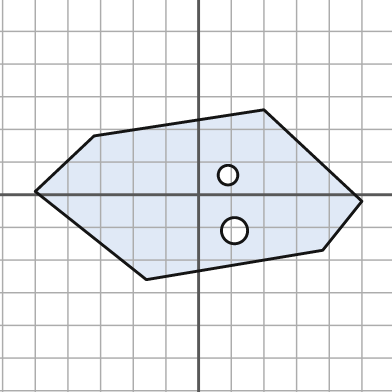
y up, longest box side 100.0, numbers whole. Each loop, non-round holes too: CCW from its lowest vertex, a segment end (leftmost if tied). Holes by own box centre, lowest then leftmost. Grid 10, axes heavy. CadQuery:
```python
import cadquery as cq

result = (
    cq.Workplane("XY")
    .moveTo(-16.0, -26.0)
    .lineTo(38.0, -17.0)
    .lineTo(50.0, -2.0)
    .lineTo(20.0, 26.0)
    .lineTo(-32.0, 18.0)
    .lineTo(-50.0, 1.0)
    .close()
    .moveTo(11.0, -11.0)
    .circle(4.0)
    .moveTo(9.0, 6.0)
    .circle(3.0)
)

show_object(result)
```